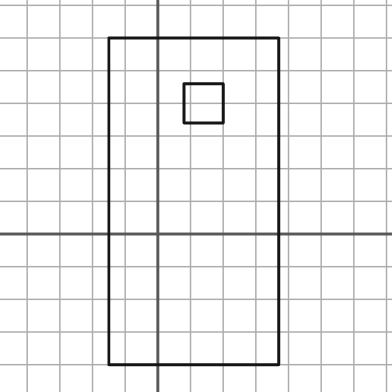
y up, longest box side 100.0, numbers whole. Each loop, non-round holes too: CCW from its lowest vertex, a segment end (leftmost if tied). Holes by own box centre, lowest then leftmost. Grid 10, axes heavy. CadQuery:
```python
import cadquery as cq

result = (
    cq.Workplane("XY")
    .moveTo(-15.0, -40.0)
    .lineTo(37.0, -40.0)
    .lineTo(37.0, 60.0)
    .lineTo(-15.0, 60.0)
    .close()
    .moveTo(8.0, 34.0)
    .lineTo(20.0, 34.0)
    .lineTo(20.0, 46.0)
    .lineTo(8.0, 46.0)
    .close()
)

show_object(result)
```